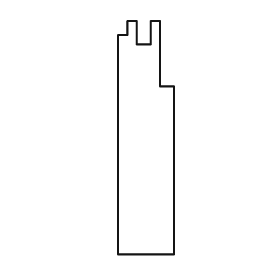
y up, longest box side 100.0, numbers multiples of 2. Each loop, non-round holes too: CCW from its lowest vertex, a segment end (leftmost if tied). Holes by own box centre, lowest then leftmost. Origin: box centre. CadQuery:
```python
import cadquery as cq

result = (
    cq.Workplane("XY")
    .moveTo(-12.0, -50.0)
    .lineTo(12.0, -50.0)
    .lineTo(12.0, 22.0)
    .lineTo(6.0, 22.0)
    .lineTo(6.0, 50.0)
    .lineTo(2.0, 50.0)
    .lineTo(2.0, 40.0)
    .lineTo(-4.0, 40.0)
    .lineTo(-4.0, 50.0)
    .lineTo(-8.0, 50.0)
    .lineTo(-8.0, 44.0)
    .lineTo(-12.0, 44.0)
    .close()
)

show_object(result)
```